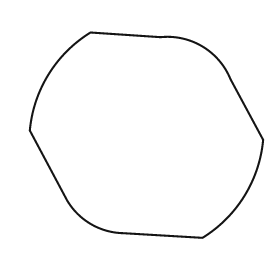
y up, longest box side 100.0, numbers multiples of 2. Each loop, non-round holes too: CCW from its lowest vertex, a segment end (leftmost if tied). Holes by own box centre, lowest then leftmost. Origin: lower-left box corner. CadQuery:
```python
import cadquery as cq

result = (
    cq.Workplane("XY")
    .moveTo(74.0, 0.0)
    .threePointArc((92.0, 18.0), (100.0, 42.0))
    .lineTo(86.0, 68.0)
    .threePointArc((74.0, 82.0), (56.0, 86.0))
    .lineTo(26.0, 88.0)
    .threePointArc((8.0, 70.0), (0.0, 46.0))
    .lineTo(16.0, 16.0)
    .threePointArc((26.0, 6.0), (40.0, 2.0))
    .close()
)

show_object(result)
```